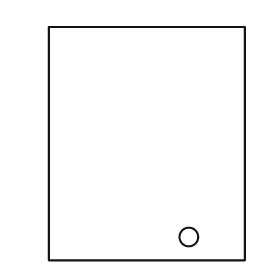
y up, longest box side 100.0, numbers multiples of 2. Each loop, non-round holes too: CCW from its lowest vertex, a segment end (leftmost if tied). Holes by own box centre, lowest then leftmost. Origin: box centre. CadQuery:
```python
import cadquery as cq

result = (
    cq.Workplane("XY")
    .moveTo(-42.0, -50.0)
    .lineTo(42.0, -50.0)
    .lineTo(42.0, 50.0)
    .lineTo(-42.0, 50.0)
    .close()
    .moveTo(18.0, -40.0)
    .circle(4.0)
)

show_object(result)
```